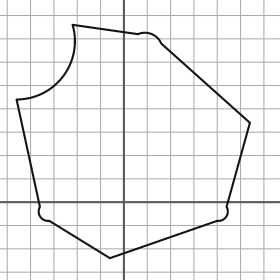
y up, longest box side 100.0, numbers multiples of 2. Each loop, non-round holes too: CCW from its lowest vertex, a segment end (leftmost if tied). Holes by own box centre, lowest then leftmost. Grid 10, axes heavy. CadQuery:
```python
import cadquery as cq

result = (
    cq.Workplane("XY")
    .moveTo(-6.0, -24.0)
    .lineTo(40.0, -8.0)
    .threePointArc((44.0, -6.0), (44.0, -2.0))
    .lineTo(54.0, 34.0)
    .lineTo(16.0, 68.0)
    .threePointArc((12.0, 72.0), (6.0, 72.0))
    .lineTo(-22.0, 76.0)
    .threePointArc((-26.0, 54.0), (-46.0, 44.0))
    .lineTo(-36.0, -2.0)
    .threePointArc((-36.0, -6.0), (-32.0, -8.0))
    .close()
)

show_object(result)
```